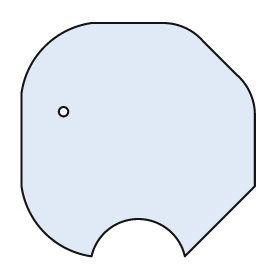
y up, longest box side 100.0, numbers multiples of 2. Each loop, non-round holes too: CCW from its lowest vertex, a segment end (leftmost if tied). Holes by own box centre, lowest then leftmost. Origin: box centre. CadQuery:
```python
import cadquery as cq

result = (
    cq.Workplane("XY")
    .moveTo(-20.0, -50.0)
    .threePointArc((0.0, -34.0), (20.0, -50.0))
    .lineTo(50.0, -20.0)
    .lineTo(50.0, 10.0)
    .threePointArc((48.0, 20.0), (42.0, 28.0))
    .lineTo(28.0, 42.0)
    .threePointArc((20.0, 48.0), (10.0, 50.0))
    .lineTo(-20.0, 50.0)
    .threePointArc((-40.0, 40.0), (-50.0, 20.0))
    .lineTo(-50.0, -20.0)
    .threePointArc((-40.0, -40.0), (-20.0, -50.0))
    .close()
    .moveTo(-32.0, 12.0)
    .circle(2.0)
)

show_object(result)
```